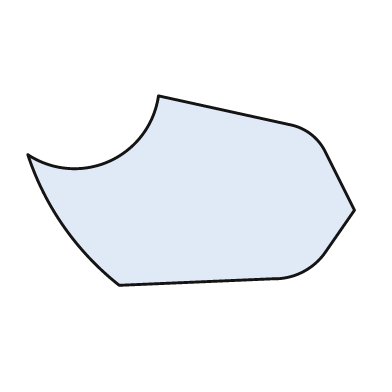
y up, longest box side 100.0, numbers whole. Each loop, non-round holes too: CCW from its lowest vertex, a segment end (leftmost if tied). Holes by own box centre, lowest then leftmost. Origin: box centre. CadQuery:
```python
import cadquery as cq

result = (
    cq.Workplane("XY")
    .moveTo(-22.0, -29.0)
    .lineTo(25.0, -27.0)
    .threePointArc((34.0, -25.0), (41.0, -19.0))
    .lineTo(50.0, -6.0)
    .lineTo(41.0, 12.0)
    .threePointArc((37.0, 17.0), (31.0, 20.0))
    .lineTo(-10.0, 29.0)
    .threePointArc((-25.0, 9.0), (-50.0, 11.0))
    .threePointArc((-39.0, -11.0), (-22.0, -29.0))
    .close()
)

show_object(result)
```